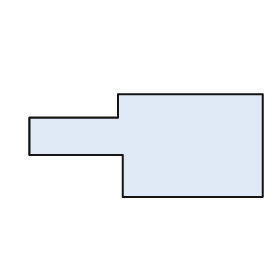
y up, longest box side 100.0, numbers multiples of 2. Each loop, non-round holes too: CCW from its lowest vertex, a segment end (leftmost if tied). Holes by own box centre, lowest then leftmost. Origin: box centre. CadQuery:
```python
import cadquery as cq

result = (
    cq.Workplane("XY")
    .moveTo(-10.0, -22.0)
    .lineTo(50.0, -22.0)
    .lineTo(50.0, 22.0)
    .lineTo(-12.0, 22.0)
    .lineTo(-12.0, 12.0)
    .lineTo(-50.0, 12.0)
    .lineTo(-50.0, -4.0)
    .lineTo(-10.0, -4.0)
    .close()
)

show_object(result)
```